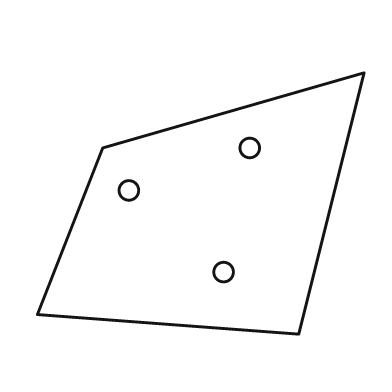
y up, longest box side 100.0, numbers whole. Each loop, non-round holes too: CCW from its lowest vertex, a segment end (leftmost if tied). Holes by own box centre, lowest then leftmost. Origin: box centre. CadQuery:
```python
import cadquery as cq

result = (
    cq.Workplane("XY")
    .moveTo(30.0, -40.0)
    .lineTo(50.0, 40.0)
    .lineTo(-30.0, 17.0)
    .lineTo(-50.0, -34.0)
    .close()
    .moveTo(7.0, -21.0)
    .circle(3.0)
    .moveTo(-22.0, 4.0)
    .circle(3.0)
    .moveTo(15.0, 17.0)
    .circle(3.0)
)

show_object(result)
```